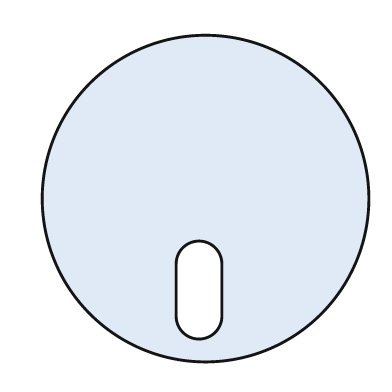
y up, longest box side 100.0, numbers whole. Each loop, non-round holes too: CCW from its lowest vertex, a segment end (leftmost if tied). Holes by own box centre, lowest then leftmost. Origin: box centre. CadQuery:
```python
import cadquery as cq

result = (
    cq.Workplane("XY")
    .moveTo(0.0, 0.0)
    .circle(50.0)
    .moveTo(-9.0, -36.0)
    .threePointArc((-2.0, -43.0), (5.0, -36.0))
    .lineTo(5.0, -20.0)
    .threePointArc((-2.0, -13.0), (-9.0, -20.0))
    .close()
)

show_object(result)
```